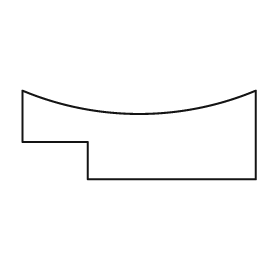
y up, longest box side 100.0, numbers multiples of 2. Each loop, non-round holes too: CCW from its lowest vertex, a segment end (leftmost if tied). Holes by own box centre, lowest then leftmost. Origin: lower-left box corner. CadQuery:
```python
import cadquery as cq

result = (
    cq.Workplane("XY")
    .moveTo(28.0, 0.0)
    .lineTo(100.0, 0.0)
    .lineTo(100.0, 38.0)
    .threePointArc((50.0, 28.0), (0.0, 38.0))
    .lineTo(0.0, 16.0)
    .lineTo(28.0, 16.0)
    .close()
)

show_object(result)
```